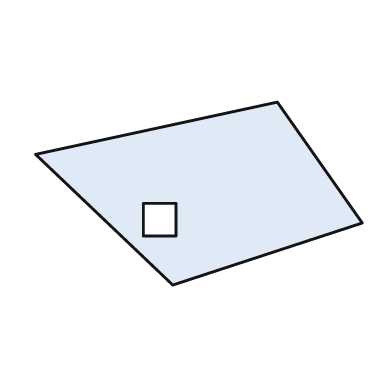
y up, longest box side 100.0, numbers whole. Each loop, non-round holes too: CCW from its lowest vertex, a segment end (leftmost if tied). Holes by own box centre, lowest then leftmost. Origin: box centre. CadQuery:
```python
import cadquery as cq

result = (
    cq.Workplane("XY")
    .moveTo(-8.0, -28.0)
    .lineTo(50.0, -9.0)
    .lineTo(24.0, 28.0)
    .lineTo(-50.0, 12.0)
    .close()
    .moveTo(-17.0, -13.0)
    .lineTo(-7.0, -13.0)
    .lineTo(-7.0, -3.0)
    .lineTo(-17.0, -3.0)
    .close()
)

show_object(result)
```